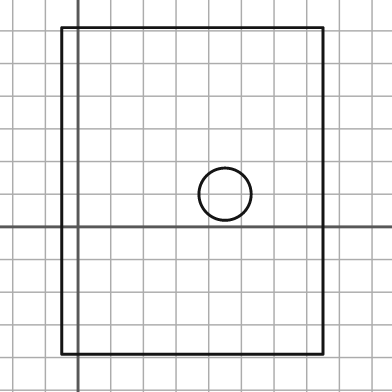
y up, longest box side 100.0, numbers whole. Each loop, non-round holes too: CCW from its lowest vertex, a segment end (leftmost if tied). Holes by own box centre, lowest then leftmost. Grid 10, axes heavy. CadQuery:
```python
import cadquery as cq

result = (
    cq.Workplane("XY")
    .moveTo(-5.0, -39.0)
    .lineTo(75.0, -39.0)
    .lineTo(75.0, 61.0)
    .lineTo(-5.0, 61.0)
    .close()
    .moveTo(45.0, 10.0)
    .circle(8.0)
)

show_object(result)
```